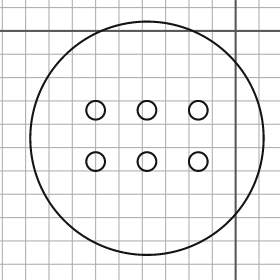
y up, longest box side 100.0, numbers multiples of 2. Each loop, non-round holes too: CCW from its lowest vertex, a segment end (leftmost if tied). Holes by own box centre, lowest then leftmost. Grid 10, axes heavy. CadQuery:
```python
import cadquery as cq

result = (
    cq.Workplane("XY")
    .moveTo(-38.0, -46.0)
    .circle(50.0)
    .moveTo(-60.0, -56.0)
    .circle(4.0)
    .moveTo(-38.0, -56.0)
    .circle(4.0)
    .moveTo(-16.0, -56.0)
    .circle(4.0)
    .moveTo(-60.0, -34.0)
    .circle(4.0)
    .moveTo(-38.0, -34.0)
    .circle(4.0)
    .moveTo(-16.0, -34.0)
    .circle(4.0)
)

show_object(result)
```